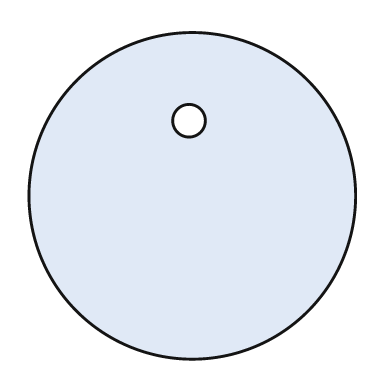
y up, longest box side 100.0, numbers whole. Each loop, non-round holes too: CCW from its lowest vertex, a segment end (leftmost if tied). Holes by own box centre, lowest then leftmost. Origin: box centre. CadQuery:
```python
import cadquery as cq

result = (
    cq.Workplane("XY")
    .moveTo(0.0, 0.0)
    .circle(50.0)
    .moveTo(-1.0, 23.0)
    .circle(5.0)
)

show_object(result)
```